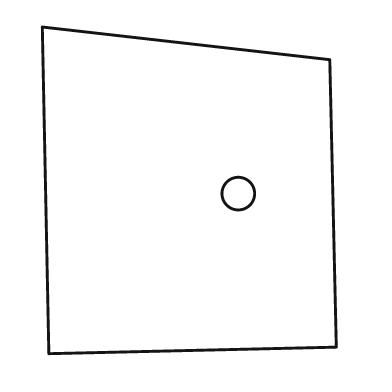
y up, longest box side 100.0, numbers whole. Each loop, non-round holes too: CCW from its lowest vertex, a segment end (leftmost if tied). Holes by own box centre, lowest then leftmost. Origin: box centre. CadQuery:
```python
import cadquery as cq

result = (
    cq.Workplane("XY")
    .moveTo(-43.0, -50.0)
    .lineTo(45.0, -48.0)
    .lineTo(43.0, 40.0)
    .lineTo(-45.0, 50.0)
    .close()
    .moveTo(15.0, -1.0)
    .circle(5.0)
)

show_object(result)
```